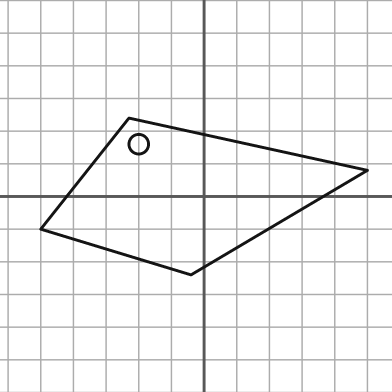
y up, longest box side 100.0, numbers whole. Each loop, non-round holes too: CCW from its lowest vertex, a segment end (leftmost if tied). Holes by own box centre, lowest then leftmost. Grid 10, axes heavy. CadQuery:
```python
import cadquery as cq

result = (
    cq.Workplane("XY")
    .moveTo(-4.0, -24.0)
    .lineTo(50.0, 8.0)
    .lineTo(-23.0, 24.0)
    .lineTo(-50.0, -10.0)
    .close()
    .moveTo(-20.0, 16.0)
    .circle(3.0)
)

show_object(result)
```